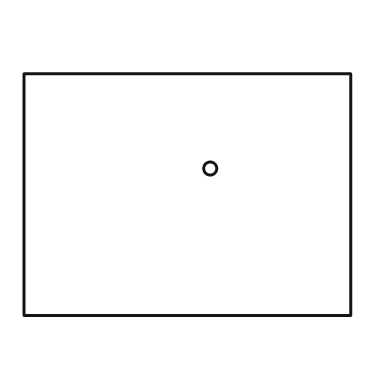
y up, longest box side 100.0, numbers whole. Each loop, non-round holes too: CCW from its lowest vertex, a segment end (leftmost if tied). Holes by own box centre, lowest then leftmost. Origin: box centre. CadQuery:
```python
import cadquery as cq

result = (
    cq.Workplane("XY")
    .moveTo(-50.0, -37.0)
    .lineTo(50.0, -37.0)
    .lineTo(50.0, 37.0)
    .lineTo(-50.0, 37.0)
    .close()
    .moveTo(7.0, 8.0)
    .circle(2.0)
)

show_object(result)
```